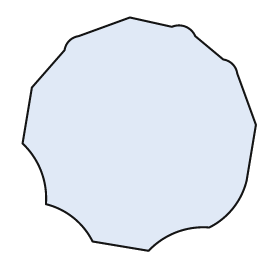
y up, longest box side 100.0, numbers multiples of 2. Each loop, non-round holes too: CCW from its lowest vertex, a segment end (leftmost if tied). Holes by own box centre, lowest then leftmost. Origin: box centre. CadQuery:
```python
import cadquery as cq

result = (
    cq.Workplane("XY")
    .moveTo(4.0, -50.0)
    .threePointArc((16.0, -42.0), (30.0, -40.0))
    .threePointArc((40.0, -32.0), (46.0, -20.0))
    .lineTo(50.0, 4.0)
    .lineTo(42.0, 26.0)
    .threePointArc((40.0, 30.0), (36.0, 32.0))
    .lineTo(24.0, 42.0)
    .threePointArc((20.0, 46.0), (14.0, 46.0))
    .lineTo(-4.0, 50.0)
    .lineTo(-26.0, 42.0)
    .threePointArc((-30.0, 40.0), (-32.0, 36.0))
    .lineTo(-46.0, 20.0)
    .lineTo(-50.0, -4.0)
    .threePointArc((-42.0, -16.0), (-40.0, -30.0))
    .threePointArc((-28.0, -36.0), (-20.0, -46.0))
    .close()
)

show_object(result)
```